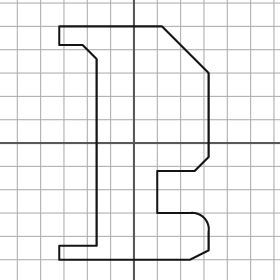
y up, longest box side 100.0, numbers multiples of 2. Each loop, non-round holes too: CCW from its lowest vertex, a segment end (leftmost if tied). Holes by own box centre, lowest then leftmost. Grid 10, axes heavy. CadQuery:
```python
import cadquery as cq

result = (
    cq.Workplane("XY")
    .moveTo(-32.0, -50.0)
    .lineTo(24.0, -50.0)
    .lineTo(32.0, -46.0)
    .lineTo(32.0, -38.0)
    .threePointArc((30.0, -32.0), (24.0, -30.0))
    .lineTo(10.0, -30.0)
    .lineTo(10.0, -12.0)
    .lineTo(26.0, -12.0)
    .lineTo(32.0, -6.0)
    .lineTo(32.0, 30.0)
    .lineTo(12.0, 50.0)
    .lineTo(-32.0, 50.0)
    .lineTo(-32.0, 42.0)
    .lineTo(-22.0, 42.0)
    .lineTo(-16.0, 36.0)
    .lineTo(-16.0, -44.0)
    .lineTo(-32.0, -44.0)
    .close()
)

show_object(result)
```